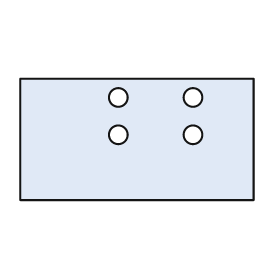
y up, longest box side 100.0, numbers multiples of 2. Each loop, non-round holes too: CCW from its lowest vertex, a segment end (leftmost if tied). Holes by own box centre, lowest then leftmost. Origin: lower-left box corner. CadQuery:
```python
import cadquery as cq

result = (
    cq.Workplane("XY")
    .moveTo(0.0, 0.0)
    .lineTo(100.0, 0.0)
    .lineTo(100.0, 52.0)
    .lineTo(0.0, 52.0)
    .close()
    .moveTo(42.0, 28.0)
    .circle(4.0)
    .moveTo(74.0, 28.0)
    .circle(4.0)
    .moveTo(42.0, 44.0)
    .circle(4.0)
    .moveTo(74.0, 44.0)
    .circle(4.0)
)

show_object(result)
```